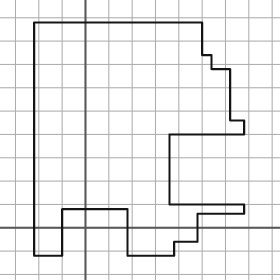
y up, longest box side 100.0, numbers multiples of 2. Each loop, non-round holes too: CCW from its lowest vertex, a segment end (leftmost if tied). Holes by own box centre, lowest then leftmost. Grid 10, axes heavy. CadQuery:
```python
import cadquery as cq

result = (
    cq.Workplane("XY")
    .moveTo(-22.0, -12.0)
    .lineTo(-10.0, -12.0)
    .lineTo(-10.0, 8.0)
    .lineTo(18.0, 8.0)
    .lineTo(18.0, -12.0)
    .lineTo(38.0, -12.0)
    .lineTo(38.0, -6.0)
    .lineTo(48.0, -6.0)
    .lineTo(48.0, 6.0)
    .lineTo(68.0, 6.0)
    .lineTo(68.0, 10.0)
    .lineTo(36.0, 10.0)
    .lineTo(36.0, 40.0)
    .lineTo(68.0, 40.0)
    .lineTo(68.0, 46.0)
    .lineTo(62.0, 46.0)
    .lineTo(62.0, 68.0)
    .lineTo(54.0, 68.0)
    .lineTo(54.0, 74.0)
    .lineTo(50.0, 74.0)
    .lineTo(50.0, 88.0)
    .lineTo(-22.0, 88.0)
    .close()
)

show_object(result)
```